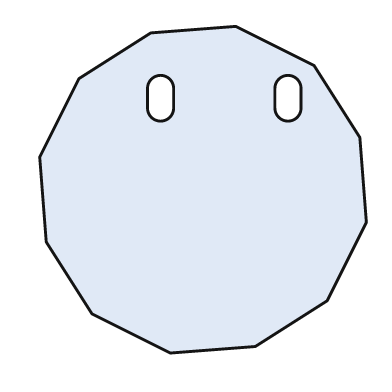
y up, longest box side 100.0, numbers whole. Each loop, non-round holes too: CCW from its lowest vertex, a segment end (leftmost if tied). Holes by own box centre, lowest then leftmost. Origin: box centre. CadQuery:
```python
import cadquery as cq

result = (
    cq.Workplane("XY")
    .moveTo(-10.0, -50.0)
    .lineTo(16.0, -48.0)
    .lineTo(38.0, -34.0)
    .lineTo(50.0, -10.0)
    .lineTo(48.0, 16.0)
    .lineTo(34.0, 38.0)
    .lineTo(10.0, 50.0)
    .lineTo(-16.0, 48.0)
    .lineTo(-38.0, 34.0)
    .lineTo(-50.0, 10.0)
    .lineTo(-48.0, -16.0)
    .lineTo(-34.0, -38.0)
    .close()
    .moveTo(-17.0, 25.0)
    .threePointArc((-13.0, 21.0), (-9.0, 25.0))
    .lineTo(-9.0, 31.0)
    .threePointArc((-13.0, 35.0), (-17.0, 31.0))
    .close()
    .moveTo(22.0, 25.0)
    .threePointArc((26.0, 21.0), (30.0, 25.0))
    .lineTo(30.0, 31.0)
    .threePointArc((26.0, 35.0), (22.0, 31.0))
    .close()
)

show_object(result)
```